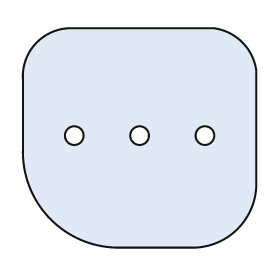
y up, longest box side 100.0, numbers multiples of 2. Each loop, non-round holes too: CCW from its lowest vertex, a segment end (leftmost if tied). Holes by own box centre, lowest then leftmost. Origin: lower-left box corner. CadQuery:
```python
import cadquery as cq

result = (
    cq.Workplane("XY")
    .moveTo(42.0, 0.0)
    .lineTo(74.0, 0.0)
    .threePointArc((92.0, 8.0), (100.0, 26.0))
    .lineTo(100.0, 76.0)
    .threePointArc((94.0, 88.0), (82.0, 94.0))
    .lineTo(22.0, 94.0)
    .threePointArc((6.0, 88.0), (0.0, 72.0))
    .lineTo(0.0, 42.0)
    .threePointArc((12.0, 12.0), (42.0, 0.0))
    .close()
    .moveTo(22.0, 48.0)
    .circle(4.0)
    .moveTo(50.0, 48.0)
    .circle(4.0)
    .moveTo(78.0, 48.0)
    .circle(4.0)
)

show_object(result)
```